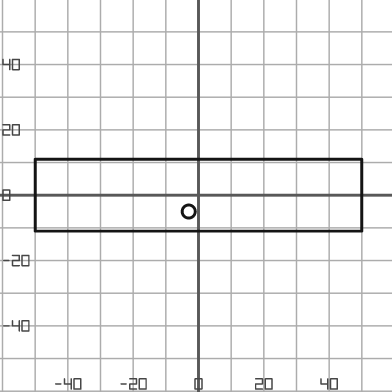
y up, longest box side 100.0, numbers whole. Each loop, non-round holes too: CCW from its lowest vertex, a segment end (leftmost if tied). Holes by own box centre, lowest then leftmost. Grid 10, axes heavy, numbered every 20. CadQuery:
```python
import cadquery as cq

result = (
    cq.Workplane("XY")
    .moveTo(-50.0, -11.0)
    .lineTo(50.0, -11.0)
    .lineTo(50.0, 11.0)
    .lineTo(-50.0, 11.0)
    .close()
    .moveTo(-3.0, -5.0)
    .circle(2.0)
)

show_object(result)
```